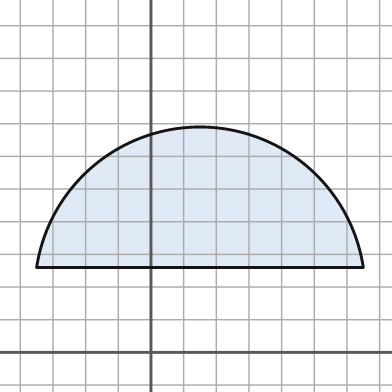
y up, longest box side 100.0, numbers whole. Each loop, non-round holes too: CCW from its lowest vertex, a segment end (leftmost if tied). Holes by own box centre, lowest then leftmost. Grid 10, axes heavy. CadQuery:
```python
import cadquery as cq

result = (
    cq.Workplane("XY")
    .moveTo(-35.0, 26.0)
    .lineTo(65.0, 26.0)
    .threePointArc((15.0, 69.0), (-35.0, 26.0))
    .close()
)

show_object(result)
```